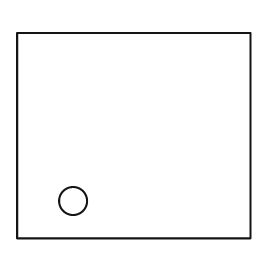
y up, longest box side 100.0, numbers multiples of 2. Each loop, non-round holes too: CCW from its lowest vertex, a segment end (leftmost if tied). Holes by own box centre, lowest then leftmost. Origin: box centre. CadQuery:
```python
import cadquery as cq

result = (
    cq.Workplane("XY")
    .moveTo(-50.0, -44.0)
    .lineTo(50.0, -44.0)
    .lineTo(50.0, 44.0)
    .lineTo(-50.0, 44.0)
    .close()
    .moveTo(-26.0, -28.0)
    .circle(6.0)
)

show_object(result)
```